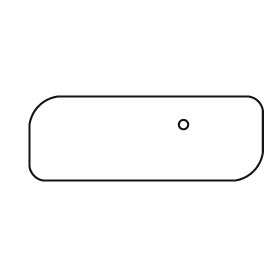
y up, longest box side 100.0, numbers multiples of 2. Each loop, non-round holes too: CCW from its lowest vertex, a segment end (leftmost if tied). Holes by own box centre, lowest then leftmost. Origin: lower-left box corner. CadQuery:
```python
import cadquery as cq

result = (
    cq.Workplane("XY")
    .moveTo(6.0, 0.0)
    .lineTo(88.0, 0.0)
    .threePointArc((96.0, 4.0), (100.0, 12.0))
    .lineTo(100.0, 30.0)
    .threePointArc((98.0, 34.0), (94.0, 36.0))
    .lineTo(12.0, 36.0)
    .threePointArc((4.0, 32.0), (0.0, 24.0))
    .lineTo(0.0, 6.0)
    .threePointArc((2.0, 2.0), (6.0, 0.0))
    .close()
    .moveTo(66.0, 24.0)
    .circle(2.0)
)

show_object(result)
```